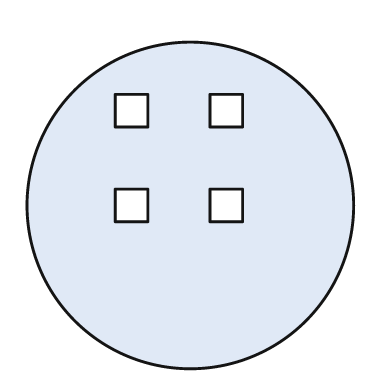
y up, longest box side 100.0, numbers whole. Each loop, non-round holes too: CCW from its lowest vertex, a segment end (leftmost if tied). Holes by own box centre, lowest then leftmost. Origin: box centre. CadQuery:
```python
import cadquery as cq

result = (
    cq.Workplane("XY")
    .moveTo(0.0, 0.0)
    .circle(50.0)
    .moveTo(-23.0, -5.0)
    .lineTo(-13.0, -5.0)
    .lineTo(-13.0, 5.0)
    .lineTo(-23.0, 5.0)
    .close()
    .moveTo(6.0, -5.0)
    .lineTo(16.0, -5.0)
    .lineTo(16.0, 5.0)
    .lineTo(6.0, 5.0)
    .close()
    .moveTo(-23.0, 24.0)
    .lineTo(-13.0, 24.0)
    .lineTo(-13.0, 34.0)
    .lineTo(-23.0, 34.0)
    .close()
    .moveTo(6.0, 24.0)
    .lineTo(16.0, 24.0)
    .lineTo(16.0, 34.0)
    .lineTo(6.0, 34.0)
    .close()
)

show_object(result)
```